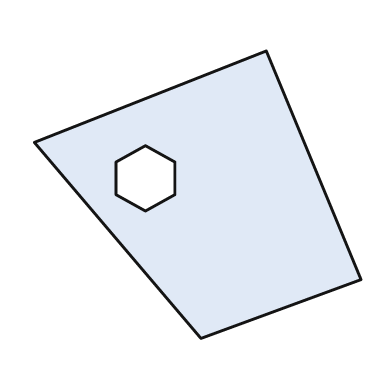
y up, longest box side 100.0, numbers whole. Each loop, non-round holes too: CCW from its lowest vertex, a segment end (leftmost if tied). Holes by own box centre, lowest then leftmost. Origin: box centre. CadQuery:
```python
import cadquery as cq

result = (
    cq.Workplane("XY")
    .moveTo(1.0, -44.0)
    .lineTo(50.0, -26.0)
    .lineTo(21.0, 44.0)
    .lineTo(-50.0, 16.0)
    .close()
    .moveTo(-16.0, -5.0)
    .lineTo(-7.0, 0.0)
    .lineTo(-7.0, 10.0)
    .lineTo(-16.0, 15.0)
    .lineTo(-25.0, 10.0)
    .lineTo(-25.0, 0.0)
    .close()
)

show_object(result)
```